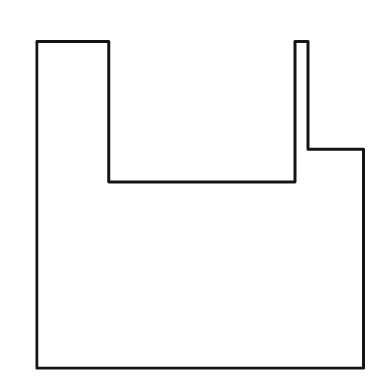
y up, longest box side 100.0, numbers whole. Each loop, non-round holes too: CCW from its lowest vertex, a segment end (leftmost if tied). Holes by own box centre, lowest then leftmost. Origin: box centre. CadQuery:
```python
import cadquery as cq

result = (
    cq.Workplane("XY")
    .moveTo(-50.0, -50.0)
    .lineTo(50.0, -50.0)
    .lineTo(50.0, 17.0)
    .lineTo(33.0, 17.0)
    .lineTo(33.0, 50.0)
    .lineTo(29.0, 50.0)
    .lineTo(29.0, 7.0)
    .lineTo(-28.0, 7.0)
    .lineTo(-28.0, 50.0)
    .lineTo(-50.0, 50.0)
    .close()
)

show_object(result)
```